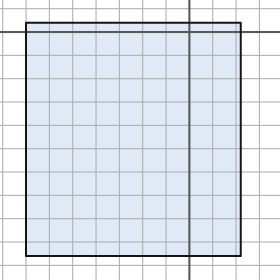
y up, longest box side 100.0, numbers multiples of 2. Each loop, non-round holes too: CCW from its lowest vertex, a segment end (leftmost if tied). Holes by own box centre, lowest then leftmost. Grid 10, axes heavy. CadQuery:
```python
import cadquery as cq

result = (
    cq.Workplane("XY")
    .moveTo(-70.0, -96.0)
    .lineTo(22.0, -96.0)
    .lineTo(22.0, 4.0)
    .lineTo(-70.0, 4.0)
    .close()
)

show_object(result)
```